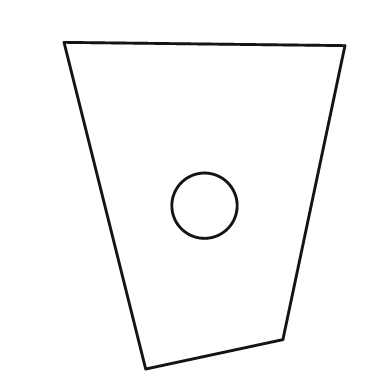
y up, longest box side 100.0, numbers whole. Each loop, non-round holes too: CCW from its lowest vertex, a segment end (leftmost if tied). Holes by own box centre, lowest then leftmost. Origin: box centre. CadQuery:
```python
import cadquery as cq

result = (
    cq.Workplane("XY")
    .moveTo(-18.0, -50.0)
    .lineTo(24.0, -41.0)
    .lineTo(43.0, 49.0)
    .lineTo(-43.0, 50.0)
    .close()
    .moveTo(0.0, 0.0)
    .circle(10.0)
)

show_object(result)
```